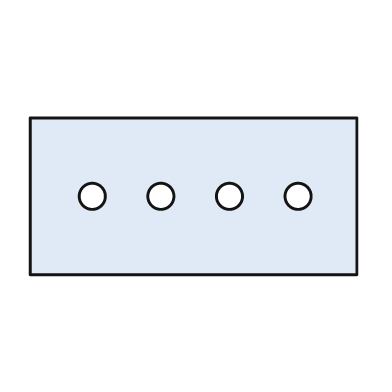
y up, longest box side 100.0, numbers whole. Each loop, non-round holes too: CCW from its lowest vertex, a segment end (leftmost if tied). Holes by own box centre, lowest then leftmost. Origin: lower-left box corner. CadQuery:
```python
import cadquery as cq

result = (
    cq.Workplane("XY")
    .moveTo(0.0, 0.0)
    .lineTo(100.0, 0.0)
    .lineTo(100.0, 48.0)
    .lineTo(0.0, 48.0)
    .close()
    .moveTo(19.0, 24.0)
    .circle(4.0)
    .moveTo(40.0, 24.0)
    .circle(4.0)
    .moveTo(61.0, 24.0)
    .circle(4.0)
    .moveTo(82.0, 24.0)
    .circle(4.0)
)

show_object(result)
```